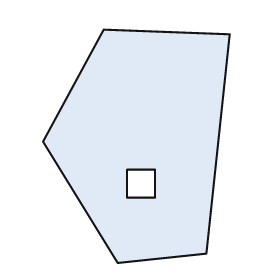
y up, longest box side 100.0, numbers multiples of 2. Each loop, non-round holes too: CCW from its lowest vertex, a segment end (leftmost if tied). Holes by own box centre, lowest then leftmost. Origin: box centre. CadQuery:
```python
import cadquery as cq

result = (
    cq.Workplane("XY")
    .moveTo(-8.0, -50.0)
    .lineTo(30.0, -46.0)
    .lineTo(40.0, 48.0)
    .lineTo(-14.0, 50.0)
    .lineTo(-40.0, 2.0)
    .close()
    .moveTo(-4.0, -22.0)
    .lineTo(8.0, -22.0)
    .lineTo(8.0, -10.0)
    .lineTo(-4.0, -10.0)
    .close()
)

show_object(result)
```